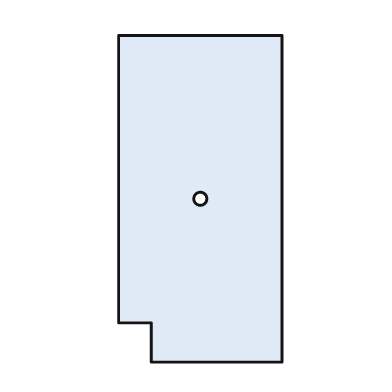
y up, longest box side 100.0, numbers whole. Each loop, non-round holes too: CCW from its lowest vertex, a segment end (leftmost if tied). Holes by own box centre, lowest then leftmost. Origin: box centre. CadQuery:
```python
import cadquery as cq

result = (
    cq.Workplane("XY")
    .moveTo(-15.0, -50.0)
    .lineTo(25.0, -50.0)
    .lineTo(25.0, 50.0)
    .lineTo(-25.0, 50.0)
    .lineTo(-25.0, -38.0)
    .lineTo(-15.0, -38.0)
    .close()
    .moveTo(0.0, 0.0)
    .circle(2.0)
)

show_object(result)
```